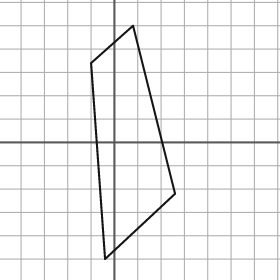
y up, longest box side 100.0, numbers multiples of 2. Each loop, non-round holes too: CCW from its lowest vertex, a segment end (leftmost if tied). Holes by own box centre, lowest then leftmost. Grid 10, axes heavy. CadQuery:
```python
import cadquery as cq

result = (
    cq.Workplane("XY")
    .moveTo(-4.0, -50.0)
    .lineTo(26.0, -22.0)
    .lineTo(8.0, 50.0)
    .lineTo(-10.0, 34.0)
    .close()
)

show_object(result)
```